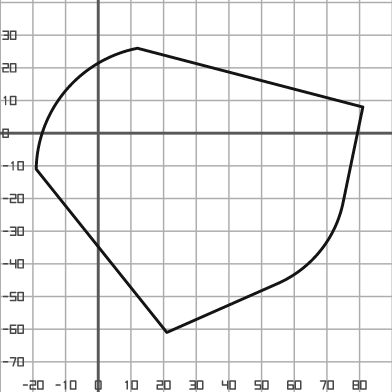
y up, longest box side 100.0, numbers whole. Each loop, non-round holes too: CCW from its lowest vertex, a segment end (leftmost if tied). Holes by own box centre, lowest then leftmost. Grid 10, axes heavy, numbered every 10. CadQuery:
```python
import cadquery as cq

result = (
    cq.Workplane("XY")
    .moveTo(21.0, -61.0)
    .lineTo(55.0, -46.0)
    .threePointArc((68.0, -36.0), (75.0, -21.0))
    .lineTo(81.0, 8.0)
    .lineTo(12.0, 26.0)
    .threePointArc((-10.0, 13.0), (-19.0, -11.0))
    .close()
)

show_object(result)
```